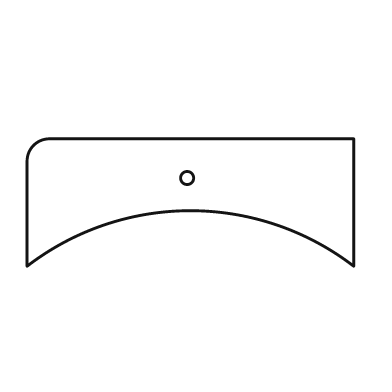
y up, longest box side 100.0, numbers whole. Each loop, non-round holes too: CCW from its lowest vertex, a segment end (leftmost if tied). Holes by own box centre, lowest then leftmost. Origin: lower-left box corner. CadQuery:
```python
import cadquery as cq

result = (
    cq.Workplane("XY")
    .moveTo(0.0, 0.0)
    .threePointArc((50.0, 17.0), (100.0, 0.0))
    .lineTo(100.0, 39.0)
    .lineTo(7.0, 39.0)
    .threePointArc((2.0, 37.0), (0.0, 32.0))
    .close()
    .moveTo(49.0, 27.0)
    .circle(2.0)
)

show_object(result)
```